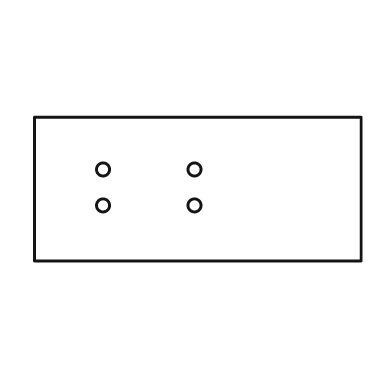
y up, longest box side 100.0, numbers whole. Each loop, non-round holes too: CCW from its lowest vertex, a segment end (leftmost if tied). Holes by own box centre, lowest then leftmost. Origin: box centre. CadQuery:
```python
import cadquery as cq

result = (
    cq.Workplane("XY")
    .moveTo(-50.0, -22.0)
    .lineTo(50.0, -22.0)
    .lineTo(50.0, 22.0)
    .lineTo(-50.0, 22.0)
    .close()
    .moveTo(-29.0, -5.0)
    .circle(2.0)
    .moveTo(-1.0, -5.0)
    .circle(2.0)
    .moveTo(-29.0, 6.0)
    .circle(2.0)
    .moveTo(-1.0, 6.0)
    .circle(2.0)
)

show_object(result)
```